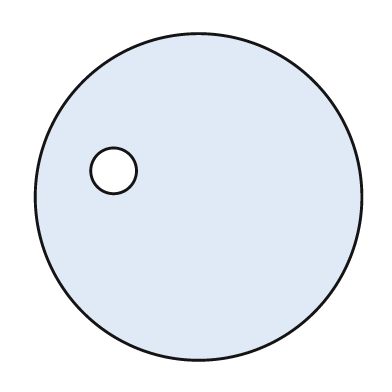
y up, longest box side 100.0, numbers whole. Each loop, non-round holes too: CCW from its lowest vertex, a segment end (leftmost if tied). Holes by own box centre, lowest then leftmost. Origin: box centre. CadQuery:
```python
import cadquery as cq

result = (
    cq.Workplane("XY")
    .moveTo(0.0, 0.0)
    .circle(50.0)
    .moveTo(-26.0, 8.0)
    .circle(7.0)
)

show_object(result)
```